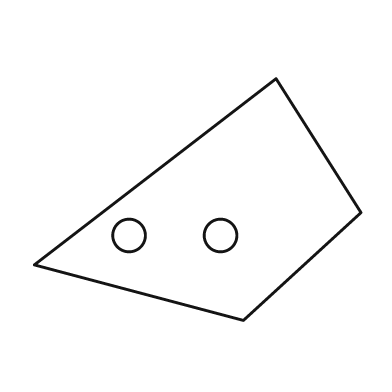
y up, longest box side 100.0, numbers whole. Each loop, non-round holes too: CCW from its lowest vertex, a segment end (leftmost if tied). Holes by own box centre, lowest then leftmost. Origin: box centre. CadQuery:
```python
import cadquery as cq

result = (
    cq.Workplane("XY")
    .moveTo(14.0, -37.0)
    .lineTo(50.0, -4.0)
    .lineTo(24.0, 37.0)
    .lineTo(-50.0, -20.0)
    .close()
    .moveTo(-21.0, -11.0)
    .circle(5.0)
    .moveTo(7.0, -11.0)
    .circle(5.0)
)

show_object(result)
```